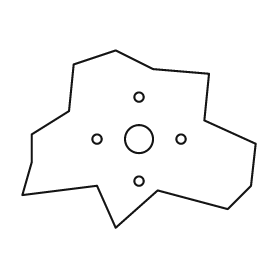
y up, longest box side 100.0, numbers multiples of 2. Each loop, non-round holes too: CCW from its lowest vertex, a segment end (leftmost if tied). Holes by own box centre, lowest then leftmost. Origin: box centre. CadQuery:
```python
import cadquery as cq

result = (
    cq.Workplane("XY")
    .moveTo(-10.0, -38.0)
    .lineTo(8.0, -22.0)
    .lineTo(38.0, -30.0)
    .lineTo(48.0, -20.0)
    .lineTo(50.0, -2.0)
    .lineTo(28.0, 8.0)
    .lineTo(30.0, 28.0)
    .lineTo(6.0, 30.0)
    .lineTo(-10.0, 38.0)
    .lineTo(-28.0, 32.0)
    .lineTo(-30.0, 12.0)
    .lineTo(-46.0, 2.0)
    .lineTo(-46.0, -10.0)
    .lineTo(-50.0, -24.0)
    .lineTo(-18.0, -20.0)
    .close()
    .moveTo(0.0, -18.0)
    .circle(2.0)
    .moveTo(-18.0, 0.0)
    .circle(2.0)
    .moveTo(0.0, 0.0)
    .circle(6.0)
    .moveTo(18.0, 0.0)
    .circle(2.0)
    .moveTo(0.0, 18.0)
    .circle(2.0)
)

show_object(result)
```